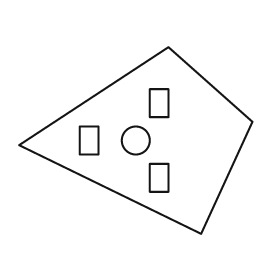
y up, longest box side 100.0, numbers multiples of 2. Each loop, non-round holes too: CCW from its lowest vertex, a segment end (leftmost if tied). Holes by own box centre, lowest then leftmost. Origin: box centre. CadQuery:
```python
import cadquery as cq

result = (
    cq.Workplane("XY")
    .moveTo(28.0, -40.0)
    .lineTo(50.0, 8.0)
    .lineTo(14.0, 40.0)
    .lineTo(-50.0, -2.0)
    .close()
    .moveTo(6.0, -22.0)
    .lineTo(14.0, -22.0)
    .lineTo(14.0, -10.0)
    .lineTo(6.0, -10.0)
    .close()
    .moveTo(-24.0, -6.0)
    .lineTo(-16.0, -6.0)
    .lineTo(-16.0, 6.0)
    .lineTo(-24.0, 6.0)
    .close()
    .moveTo(0.0, 0.0)
    .circle(6.0)
    .moveTo(6.0, 10.0)
    .lineTo(14.0, 10.0)
    .lineTo(14.0, 22.0)
    .lineTo(6.0, 22.0)
    .close()
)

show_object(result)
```